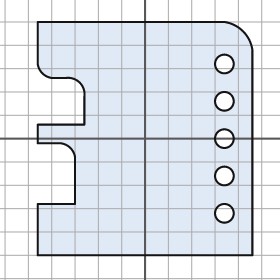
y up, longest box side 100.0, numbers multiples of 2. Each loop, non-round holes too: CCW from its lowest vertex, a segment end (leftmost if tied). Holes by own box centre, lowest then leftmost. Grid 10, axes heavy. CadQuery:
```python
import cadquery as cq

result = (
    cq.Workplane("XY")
    .moveTo(-46.0, -50.0)
    .lineTo(46.0, -50.0)
    .lineTo(46.0, 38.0)
    .threePointArc((42.0, 46.0), (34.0, 50.0))
    .lineTo(-46.0, 50.0)
    .lineTo(-46.0, 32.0)
    .threePointArc((-44.0, 28.0), (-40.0, 26.0))
    .lineTo(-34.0, 26.0)
    .threePointArc((-28.0, 24.0), (-26.0, 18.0))
    .lineTo(-26.0, 6.0)
    .lineTo(-46.0, 6.0)
    .lineTo(-46.0, -2.0)
    .lineTo(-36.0, -2.0)
    .threePointArc((-32.0, -4.0), (-30.0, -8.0))
    .lineTo(-30.0, -28.0)
    .lineTo(-46.0, -28.0)
    .close()
    .moveTo(34.0, -32.0)
    .circle(4.0)
    .moveTo(34.0, -16.0)
    .circle(4.0)
    .moveTo(34.0, 0.0)
    .circle(4.0)
    .moveTo(34.0, 16.0)
    .circle(4.0)
    .moveTo(34.0, 32.0)
    .circle(4.0)
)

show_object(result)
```